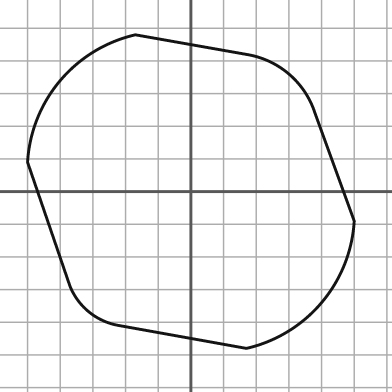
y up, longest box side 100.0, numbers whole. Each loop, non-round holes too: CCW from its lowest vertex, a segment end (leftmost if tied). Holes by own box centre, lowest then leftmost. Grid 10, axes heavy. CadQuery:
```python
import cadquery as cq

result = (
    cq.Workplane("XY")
    .moveTo(17.0, -48.0)
    .threePointArc((40.0, -34.0), (50.0, -9.0))
    .lineTo(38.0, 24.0)
    .threePointArc((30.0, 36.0), (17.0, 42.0))
    .lineTo(-17.0, 48.0)
    .threePointArc((-40.0, 34.0), (-50.0, 9.0))
    .lineTo(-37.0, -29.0)
    .threePointArc((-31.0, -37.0), (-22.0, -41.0))
    .close()
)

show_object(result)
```